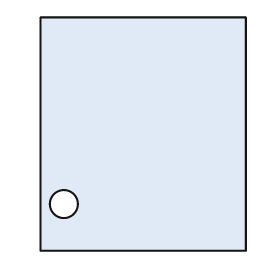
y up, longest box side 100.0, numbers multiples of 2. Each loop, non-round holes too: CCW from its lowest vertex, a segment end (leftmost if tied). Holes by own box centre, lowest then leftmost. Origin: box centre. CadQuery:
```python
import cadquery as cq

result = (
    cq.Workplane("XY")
    .moveTo(-44.0, -50.0)
    .lineTo(44.0, -50.0)
    .lineTo(44.0, 50.0)
    .lineTo(-44.0, 50.0)
    .close()
    .moveTo(-34.0, -30.0)
    .circle(6.0)
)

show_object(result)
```